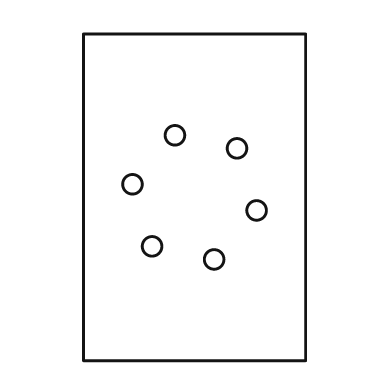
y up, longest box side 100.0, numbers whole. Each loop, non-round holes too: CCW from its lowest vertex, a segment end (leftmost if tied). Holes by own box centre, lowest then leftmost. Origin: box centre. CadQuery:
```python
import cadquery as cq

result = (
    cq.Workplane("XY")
    .moveTo(-34.0, -50.0)
    .lineTo(34.0, -50.0)
    .lineTo(34.0, 50.0)
    .lineTo(-34.0, 50.0)
    .close()
    .moveTo(6.0, -19.0)
    .circle(3.0)
    .moveTo(-13.0, -15.0)
    .circle(3.0)
    .moveTo(19.0, -4.0)
    .circle(3.0)
    .moveTo(-19.0, 4.0)
    .circle(3.0)
    .moveTo(13.0, 15.0)
    .circle(3.0)
    .moveTo(-6.0, 19.0)
    .circle(3.0)
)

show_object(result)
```